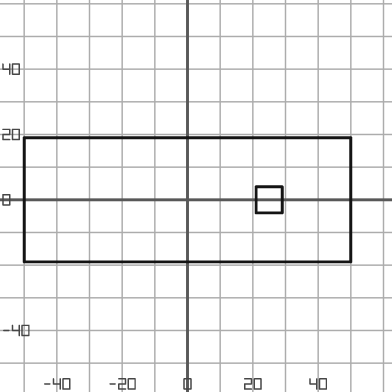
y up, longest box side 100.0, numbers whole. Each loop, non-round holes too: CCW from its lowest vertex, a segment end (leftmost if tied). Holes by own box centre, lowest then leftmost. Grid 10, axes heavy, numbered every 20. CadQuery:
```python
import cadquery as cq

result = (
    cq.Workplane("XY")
    .moveTo(-50.0, -19.0)
    .lineTo(50.0, -19.0)
    .lineTo(50.0, 19.0)
    .lineTo(-50.0, 19.0)
    .close()
    .moveTo(21.0, -4.0)
    .lineTo(29.0, -4.0)
    .lineTo(29.0, 4.0)
    .lineTo(21.0, 4.0)
    .close()
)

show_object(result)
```